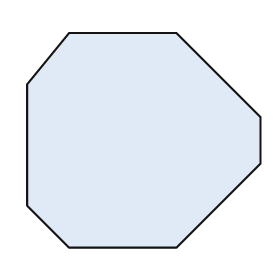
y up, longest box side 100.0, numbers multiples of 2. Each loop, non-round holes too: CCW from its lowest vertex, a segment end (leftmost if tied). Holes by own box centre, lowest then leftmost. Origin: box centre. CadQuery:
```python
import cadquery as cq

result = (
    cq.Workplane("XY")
    .moveTo(-32.0, -46.0)
    .lineTo(14.0, -46.0)
    .lineTo(50.0, -10.0)
    .lineTo(50.0, 10.0)
    .lineTo(14.0, 46.0)
    .lineTo(-32.0, 46.0)
    .lineTo(-50.0, 24.0)
    .lineTo(-50.0, -28.0)
    .close()
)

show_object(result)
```